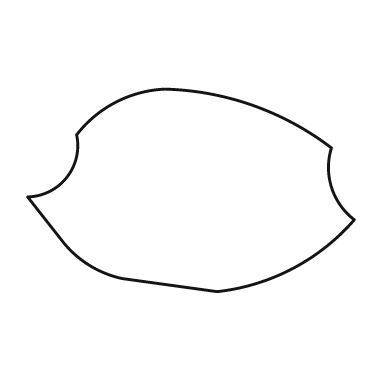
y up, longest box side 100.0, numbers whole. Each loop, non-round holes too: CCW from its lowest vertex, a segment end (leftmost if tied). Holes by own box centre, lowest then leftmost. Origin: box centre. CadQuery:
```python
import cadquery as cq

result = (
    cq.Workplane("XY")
    .moveTo(8.0, -31.0)
    .threePointArc((31.0, -24.0), (50.0, -9.0))
    .threePointArc((43.0, 1.0), (43.0, 13.0))
    .threePointArc((19.0, 26.0), (-8.0, 31.0))
    .threePointArc((-23.0, 27.0), (-35.0, 17.0))
    .threePointArc((-38.0, 4.0), (-50.0, -2.0))
    .lineTo(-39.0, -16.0)
    .threePointArc((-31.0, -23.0), (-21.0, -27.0))
    .close()
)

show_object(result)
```